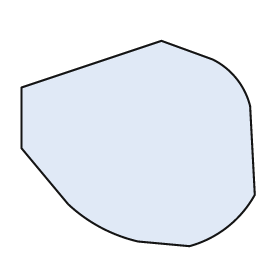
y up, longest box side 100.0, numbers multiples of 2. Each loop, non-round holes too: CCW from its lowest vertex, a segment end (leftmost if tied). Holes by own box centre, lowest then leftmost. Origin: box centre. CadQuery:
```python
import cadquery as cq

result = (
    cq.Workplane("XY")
    .moveTo(22.0, -44.0)
    .threePointArc((38.0, -36.0), (50.0, -22.0))
    .lineTo(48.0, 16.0)
    .threePointArc((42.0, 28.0), (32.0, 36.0))
    .lineTo(10.0, 44.0)
    .lineTo(-50.0, 24.0)
    .lineTo(-50.0, -2.0)
    .lineTo(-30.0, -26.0)
    .threePointArc((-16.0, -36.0), (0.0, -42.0))
    .close()
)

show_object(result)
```